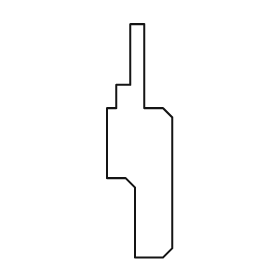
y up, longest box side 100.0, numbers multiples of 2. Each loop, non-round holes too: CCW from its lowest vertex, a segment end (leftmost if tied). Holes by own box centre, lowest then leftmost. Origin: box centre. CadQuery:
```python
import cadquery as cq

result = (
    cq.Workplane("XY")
    .moveTo(-2.0, -50.0)
    .lineTo(10.0, -50.0)
    .lineTo(14.0, -46.0)
    .lineTo(14.0, 10.0)
    .lineTo(10.0, 14.0)
    .lineTo(2.0, 14.0)
    .lineTo(2.0, 50.0)
    .lineTo(-4.0, 50.0)
    .lineTo(-4.0, 24.0)
    .lineTo(-10.0, 24.0)
    .lineTo(-10.0, 14.0)
    .lineTo(-14.0, 14.0)
    .lineTo(-14.0, -16.0)
    .lineTo(-6.0, -16.0)
    .lineTo(-2.0, -20.0)
    .close()
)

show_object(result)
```